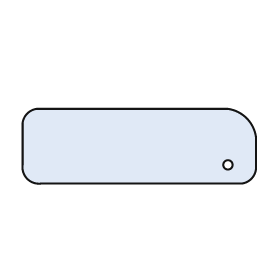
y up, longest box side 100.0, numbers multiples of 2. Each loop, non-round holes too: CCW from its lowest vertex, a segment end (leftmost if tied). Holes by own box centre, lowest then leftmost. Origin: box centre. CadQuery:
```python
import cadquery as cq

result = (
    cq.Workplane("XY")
    .moveTo(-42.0, -16.0)
    .lineTo(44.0, -16.0)
    .threePointArc((48.0, -14.0), (50.0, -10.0))
    .lineTo(50.0, 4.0)
    .threePointArc((46.0, 12.0), (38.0, 16.0))
    .lineTo(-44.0, 16.0)
    .threePointArc((-48.0, 14.0), (-50.0, 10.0))
    .lineTo(-50.0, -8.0)
    .threePointArc((-48.0, -14.0), (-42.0, -16.0))
    .close()
    .moveTo(38.0, -8.0)
    .circle(2.0)
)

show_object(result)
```